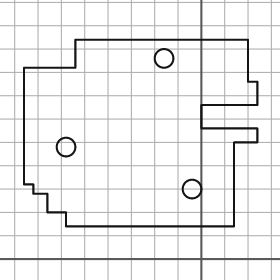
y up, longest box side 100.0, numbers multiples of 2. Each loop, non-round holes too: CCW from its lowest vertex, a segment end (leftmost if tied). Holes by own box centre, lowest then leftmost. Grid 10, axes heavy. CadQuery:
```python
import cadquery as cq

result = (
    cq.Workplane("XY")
    .moveTo(-58.0, 14.0)
    .lineTo(14.0, 14.0)
    .lineTo(14.0, 50.0)
    .lineTo(24.0, 50.0)
    .lineTo(24.0, 56.0)
    .lineTo(0.0, 56.0)
    .lineTo(0.0, 66.0)
    .lineTo(24.0, 66.0)
    .lineTo(24.0, 76.0)
    .lineTo(20.0, 76.0)
    .lineTo(20.0, 94.0)
    .lineTo(-54.0, 94.0)
    .lineTo(-54.0, 82.0)
    .lineTo(-76.0, 82.0)
    .lineTo(-76.0, 32.0)
    .lineTo(-72.0, 32.0)
    .lineTo(-72.0, 28.0)
    .lineTo(-66.0, 28.0)
    .lineTo(-66.0, 20.0)
    .lineTo(-58.0, 20.0)
    .close()
    .moveTo(-4.0, 30.0)
    .circle(4.0)
    .moveTo(-58.0, 48.0)
    .circle(4.0)
    .moveTo(-16.0, 86.0)
    .circle(4.0)
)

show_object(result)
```